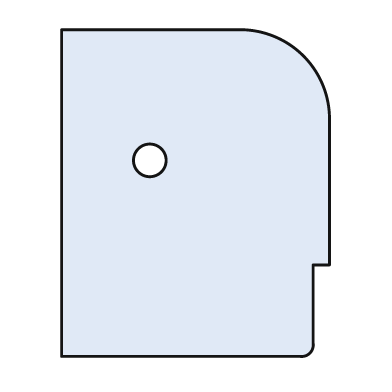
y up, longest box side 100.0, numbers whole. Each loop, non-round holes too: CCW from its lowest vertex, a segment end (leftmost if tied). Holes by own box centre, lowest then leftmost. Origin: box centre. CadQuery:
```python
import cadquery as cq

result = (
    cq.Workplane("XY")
    .moveTo(-41.0, -50.0)
    .lineTo(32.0, -50.0)
    .threePointArc((35.0, -49.0), (36.0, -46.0))
    .lineTo(36.0, -22.0)
    .lineTo(41.0, -22.0)
    .lineTo(41.0, 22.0)
    .threePointArc((33.0, 42.0), (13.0, 50.0))
    .lineTo(-41.0, 50.0)
    .close()
    .moveTo(-14.0, 10.0)
    .circle(5.0)
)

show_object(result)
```